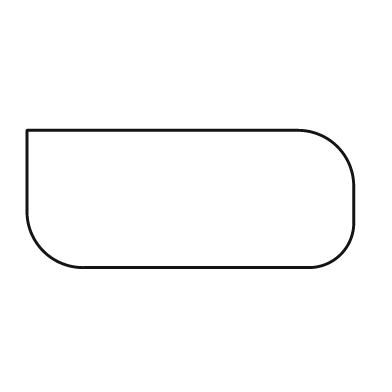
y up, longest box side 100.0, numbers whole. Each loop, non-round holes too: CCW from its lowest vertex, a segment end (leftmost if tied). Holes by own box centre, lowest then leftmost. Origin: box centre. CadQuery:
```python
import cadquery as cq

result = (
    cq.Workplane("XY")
    .moveTo(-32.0, -21.0)
    .lineTo(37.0, -21.0)
    .threePointArc((46.0, -17.0), (50.0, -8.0))
    .lineTo(50.0, 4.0)
    .threePointArc((45.0, 16.0), (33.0, 21.0))
    .lineTo(-50.0, 21.0)
    .lineTo(-50.0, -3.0)
    .threePointArc((-45.0, -16.0), (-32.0, -21.0))
    .close()
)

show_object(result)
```